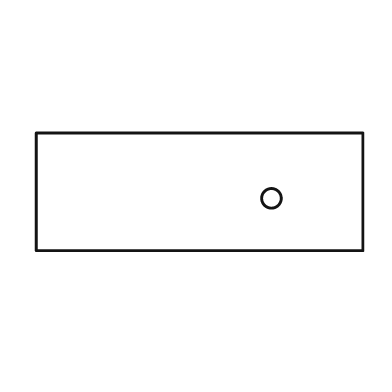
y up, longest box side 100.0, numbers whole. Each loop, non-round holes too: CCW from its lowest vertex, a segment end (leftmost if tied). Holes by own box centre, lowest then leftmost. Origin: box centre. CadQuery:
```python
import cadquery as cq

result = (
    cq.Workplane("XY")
    .moveTo(-50.0, -18.0)
    .lineTo(50.0, -18.0)
    .lineTo(50.0, 18.0)
    .lineTo(-50.0, 18.0)
    .close()
    .moveTo(22.0, -2.0)
    .circle(3.0)
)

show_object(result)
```